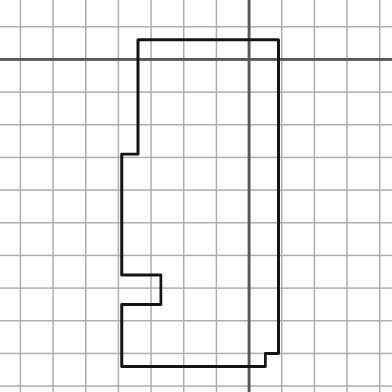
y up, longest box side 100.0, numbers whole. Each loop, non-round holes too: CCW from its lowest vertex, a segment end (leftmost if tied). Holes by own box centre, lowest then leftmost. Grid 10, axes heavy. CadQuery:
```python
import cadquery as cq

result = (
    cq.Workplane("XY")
    .moveTo(-39.0, -94.0)
    .lineTo(5.0, -94.0)
    .lineTo(5.0, -90.0)
    .lineTo(9.0, -90.0)
    .lineTo(9.0, 6.0)
    .lineTo(-34.0, 6.0)
    .lineTo(-34.0, -29.0)
    .lineTo(-39.0, -29.0)
    .lineTo(-39.0, -66.0)
    .lineTo(-27.0, -66.0)
    .lineTo(-27.0, -75.0)
    .lineTo(-39.0, -75.0)
    .close()
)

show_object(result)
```